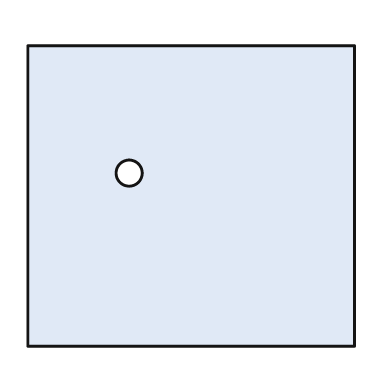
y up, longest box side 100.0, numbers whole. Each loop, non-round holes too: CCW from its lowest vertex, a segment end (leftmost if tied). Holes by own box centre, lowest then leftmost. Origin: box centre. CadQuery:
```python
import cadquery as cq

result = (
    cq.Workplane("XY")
    .moveTo(-50.0, -46.0)
    .lineTo(50.0, -46.0)
    .lineTo(50.0, 46.0)
    .lineTo(-50.0, 46.0)
    .close()
    .moveTo(-19.0, 7.0)
    .circle(4.0)
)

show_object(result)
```